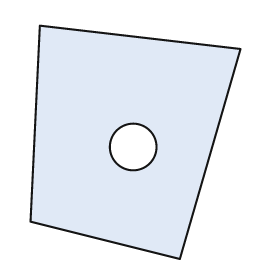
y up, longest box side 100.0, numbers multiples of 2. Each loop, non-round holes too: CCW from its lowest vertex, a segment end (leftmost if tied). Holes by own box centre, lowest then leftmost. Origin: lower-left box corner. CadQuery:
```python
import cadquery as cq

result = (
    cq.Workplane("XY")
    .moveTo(64.0, 0.0)
    .lineTo(90.0, 90.0)
    .lineTo(4.0, 100.0)
    .lineTo(0.0, 16.0)
    .close()
    .moveTo(44.0, 48.0)
    .circle(10.0)
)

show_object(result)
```